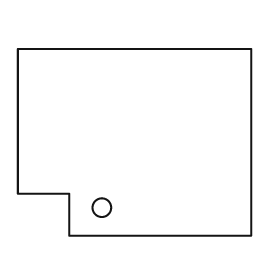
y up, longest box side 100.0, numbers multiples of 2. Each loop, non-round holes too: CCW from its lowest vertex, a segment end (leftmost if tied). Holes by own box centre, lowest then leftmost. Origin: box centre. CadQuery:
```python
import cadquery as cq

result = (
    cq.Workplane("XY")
    .moveTo(-28.0, -40.0)
    .lineTo(50.0, -40.0)
    .lineTo(50.0, 40.0)
    .lineTo(-50.0, 40.0)
    .lineTo(-50.0, -22.0)
    .lineTo(-28.0, -22.0)
    .close()
    .moveTo(-14.0, -28.0)
    .circle(4.0)
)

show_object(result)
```